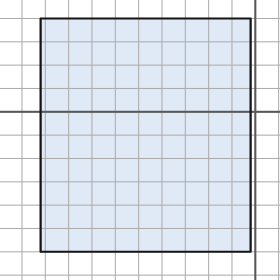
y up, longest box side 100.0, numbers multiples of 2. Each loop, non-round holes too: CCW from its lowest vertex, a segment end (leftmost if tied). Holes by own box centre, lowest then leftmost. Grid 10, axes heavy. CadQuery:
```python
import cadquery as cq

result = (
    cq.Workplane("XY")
    .moveTo(-92.0, -60.0)
    .lineTo(-2.0, -60.0)
    .lineTo(-2.0, 40.0)
    .lineTo(-92.0, 40.0)
    .close()
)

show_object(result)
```